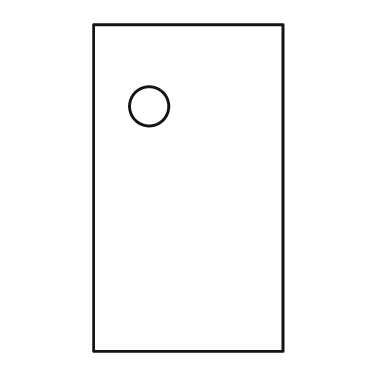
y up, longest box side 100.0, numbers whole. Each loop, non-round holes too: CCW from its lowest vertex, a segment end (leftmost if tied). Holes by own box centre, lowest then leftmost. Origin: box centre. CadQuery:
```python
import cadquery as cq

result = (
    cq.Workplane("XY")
    .moveTo(-29.0, -50.0)
    .lineTo(29.0, -50.0)
    .lineTo(29.0, 50.0)
    .lineTo(-29.0, 50.0)
    .close()
    .moveTo(-12.0, 25.0)
    .circle(6.0)
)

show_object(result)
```